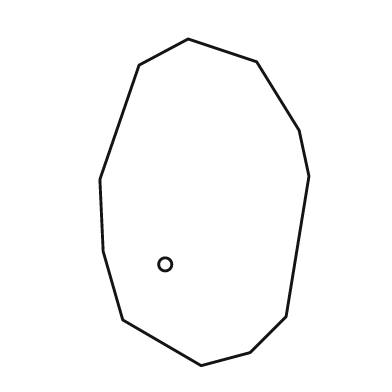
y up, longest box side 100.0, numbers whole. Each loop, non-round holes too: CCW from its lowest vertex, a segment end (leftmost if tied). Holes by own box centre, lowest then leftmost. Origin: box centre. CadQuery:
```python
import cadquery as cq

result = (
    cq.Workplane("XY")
    .moveTo(-1.0, -50.0)
    .lineTo(14.0, -46.0)
    .lineTo(25.0, -35.0)
    .lineTo(32.0, 8.0)
    .lineTo(29.0, 22.0)
    .lineTo(16.0, 43.0)
    .lineTo(-5.0, 50.0)
    .lineTo(-20.0, 42.0)
    .lineTo(-32.0, 7.0)
    .lineTo(-31.0, -15.0)
    .lineTo(-25.0, -36.0)
    .close()
    .moveTo(-12.0, -19.0)
    .circle(2.0)
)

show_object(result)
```